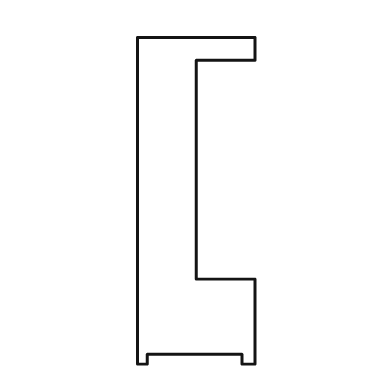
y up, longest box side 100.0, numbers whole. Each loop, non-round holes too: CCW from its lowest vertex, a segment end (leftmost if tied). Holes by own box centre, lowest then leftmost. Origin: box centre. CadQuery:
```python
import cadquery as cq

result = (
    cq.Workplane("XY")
    .moveTo(-18.0, -50.0)
    .lineTo(-15.0, -50.0)
    .lineTo(-15.0, -47.0)
    .lineTo(14.0, -47.0)
    .lineTo(14.0, -50.0)
    .lineTo(18.0, -50.0)
    .lineTo(18.0, -24.0)
    .lineTo(0.0, -24.0)
    .lineTo(0.0, 43.0)
    .lineTo(18.0, 43.0)
    .lineTo(18.0, 50.0)
    .lineTo(-18.0, 50.0)
    .close()
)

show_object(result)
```